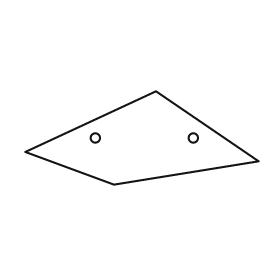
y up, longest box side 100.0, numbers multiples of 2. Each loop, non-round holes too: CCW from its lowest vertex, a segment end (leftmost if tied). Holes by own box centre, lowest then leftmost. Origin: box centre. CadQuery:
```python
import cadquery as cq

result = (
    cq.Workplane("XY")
    .moveTo(-12.0, -20.0)
    .lineTo(50.0, -10.0)
    .lineTo(6.0, 20.0)
    .lineTo(-50.0, -6.0)
    .close()
    .moveTo(-20.0, 0.0)
    .circle(2.0)
    .moveTo(22.0, 0.0)
    .circle(2.0)
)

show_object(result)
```